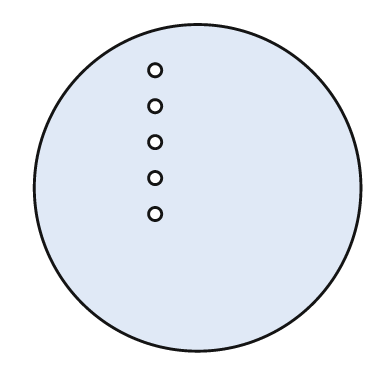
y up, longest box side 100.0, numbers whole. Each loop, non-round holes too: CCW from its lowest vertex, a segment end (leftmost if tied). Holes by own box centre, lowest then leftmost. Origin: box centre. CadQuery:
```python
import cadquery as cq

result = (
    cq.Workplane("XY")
    .moveTo(0.0, 0.0)
    .circle(50.0)
    .moveTo(-13.0, -8.0)
    .circle(2.0)
    .moveTo(-13.0, 3.0)
    .circle(2.0)
    .moveTo(-13.0, 14.0)
    .circle(2.0)
    .moveTo(-13.0, 25.0)
    .circle(2.0)
    .moveTo(-13.0, 36.0)
    .circle(2.0)
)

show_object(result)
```